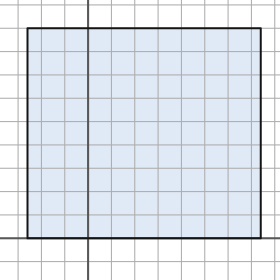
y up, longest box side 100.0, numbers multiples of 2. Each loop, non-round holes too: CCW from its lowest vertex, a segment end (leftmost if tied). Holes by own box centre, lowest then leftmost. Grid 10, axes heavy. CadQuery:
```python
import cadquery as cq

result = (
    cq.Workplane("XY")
    .moveTo(-26.0, 0.0)
    .lineTo(74.0, 0.0)
    .lineTo(74.0, 90.0)
    .lineTo(-26.0, 90.0)
    .close()
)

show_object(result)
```